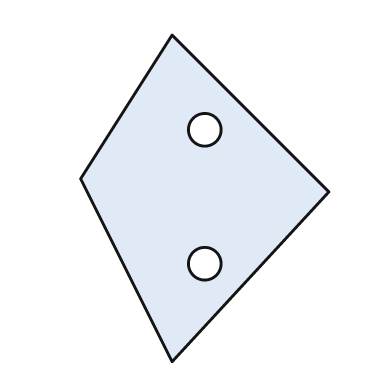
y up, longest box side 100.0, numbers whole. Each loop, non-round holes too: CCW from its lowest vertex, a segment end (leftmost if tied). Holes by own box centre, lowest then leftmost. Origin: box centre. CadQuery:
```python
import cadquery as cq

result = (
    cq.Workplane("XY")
    .moveTo(-10.0, -50.0)
    .lineTo(38.0, 2.0)
    .lineTo(-10.0, 50.0)
    .lineTo(-38.0, 6.0)
    .close()
    .moveTo(0.0, -20.0)
    .circle(5.0)
    .moveTo(0.0, 21.0)
    .circle(5.0)
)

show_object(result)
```